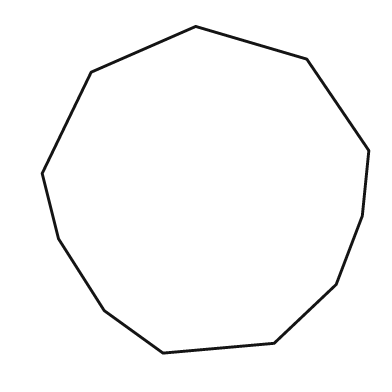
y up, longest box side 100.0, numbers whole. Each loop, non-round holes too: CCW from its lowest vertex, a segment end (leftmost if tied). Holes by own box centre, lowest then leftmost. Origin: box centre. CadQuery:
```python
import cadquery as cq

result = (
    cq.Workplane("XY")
    .moveTo(-13.0, -50.0)
    .lineTo(21.0, -47.0)
    .lineTo(40.0, -29.0)
    .lineTo(48.0, -8.0)
    .lineTo(50.0, 12.0)
    .lineTo(31.0, 40.0)
    .lineTo(-3.0, 50.0)
    .lineTo(-35.0, 36.0)
    .lineTo(-50.0, 5.0)
    .lineTo(-45.0, -15.0)
    .lineTo(-31.0, -37.0)
    .close()
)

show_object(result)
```